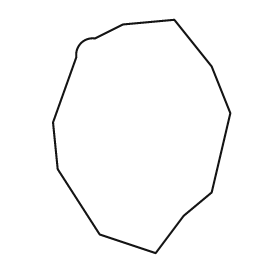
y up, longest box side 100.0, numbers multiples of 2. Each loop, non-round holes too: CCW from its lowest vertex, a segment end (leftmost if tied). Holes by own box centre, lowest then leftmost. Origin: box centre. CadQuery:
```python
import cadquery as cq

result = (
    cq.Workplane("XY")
    .moveTo(6.0, -50.0)
    .lineTo(18.0, -34.0)
    .lineTo(30.0, -24.0)
    .lineTo(38.0, 10.0)
    .lineTo(30.0, 30.0)
    .lineTo(14.0, 50.0)
    .lineTo(-8.0, 48.0)
    .lineTo(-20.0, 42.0)
    .threePointArc((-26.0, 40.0), (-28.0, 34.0))
    .lineTo(-38.0, 6.0)
    .lineTo(-36.0, -14.0)
    .lineTo(-18.0, -42.0)
    .close()
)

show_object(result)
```